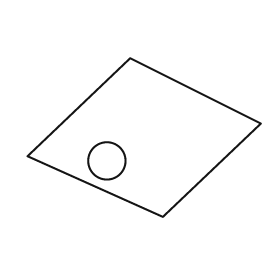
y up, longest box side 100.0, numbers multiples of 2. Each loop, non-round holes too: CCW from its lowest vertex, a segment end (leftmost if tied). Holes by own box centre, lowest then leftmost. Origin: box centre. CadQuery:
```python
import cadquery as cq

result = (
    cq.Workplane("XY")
    .moveTo(8.0, -34.0)
    .lineTo(50.0, 6.0)
    .lineTo(-6.0, 34.0)
    .lineTo(-50.0, -8.0)
    .close()
    .moveTo(-16.0, -10.0)
    .circle(8.0)
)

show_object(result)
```